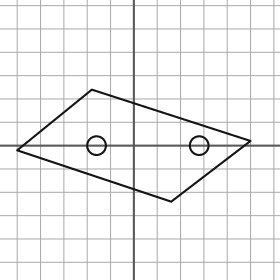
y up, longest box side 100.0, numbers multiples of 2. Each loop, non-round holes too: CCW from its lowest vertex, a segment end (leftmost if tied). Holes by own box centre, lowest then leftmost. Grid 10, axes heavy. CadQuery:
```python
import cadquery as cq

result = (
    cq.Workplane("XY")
    .moveTo(16.0, -24.0)
    .lineTo(50.0, 2.0)
    .lineTo(-18.0, 24.0)
    .lineTo(-50.0, -2.0)
    .close()
    .moveTo(-16.0, 0.0)
    .circle(4.0)
    .moveTo(28.0, 0.0)
    .circle(4.0)
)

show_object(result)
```